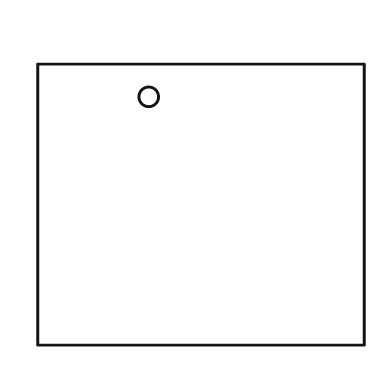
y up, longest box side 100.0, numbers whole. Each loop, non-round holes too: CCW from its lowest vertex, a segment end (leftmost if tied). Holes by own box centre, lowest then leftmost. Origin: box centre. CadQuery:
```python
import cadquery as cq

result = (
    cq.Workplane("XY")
    .moveTo(-50.0, -43.0)
    .lineTo(50.0, -43.0)
    .lineTo(50.0, 43.0)
    .lineTo(-50.0, 43.0)
    .close()
    .moveTo(-16.0, 33.0)
    .circle(3.0)
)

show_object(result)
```